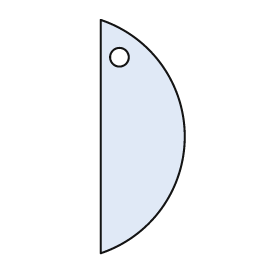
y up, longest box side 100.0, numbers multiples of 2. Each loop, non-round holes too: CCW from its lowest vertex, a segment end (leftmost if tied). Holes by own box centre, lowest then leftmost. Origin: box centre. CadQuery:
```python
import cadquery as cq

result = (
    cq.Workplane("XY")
    .moveTo(-18.0, -50.0)
    .threePointArc((18.0, 0.0), (-18.0, 50.0))
    .close()
    .moveTo(-10.0, 34.0)
    .circle(4.0)
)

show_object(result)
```